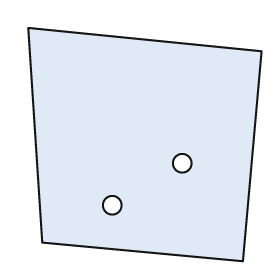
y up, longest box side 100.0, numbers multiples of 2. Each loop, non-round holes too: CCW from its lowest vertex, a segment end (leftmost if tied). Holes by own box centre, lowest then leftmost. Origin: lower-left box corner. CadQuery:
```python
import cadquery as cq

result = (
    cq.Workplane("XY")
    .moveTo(92.0, 0.0)
    .lineTo(100.0, 90.0)
    .lineTo(0.0, 100.0)
    .lineTo(6.0, 8.0)
    .close()
    .moveTo(36.0, 24.0)
    .circle(4.0)
    .moveTo(66.0, 42.0)
    .circle(4.0)
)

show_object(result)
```